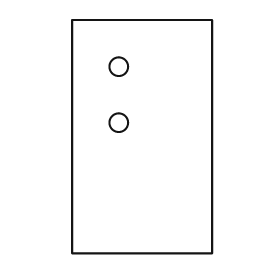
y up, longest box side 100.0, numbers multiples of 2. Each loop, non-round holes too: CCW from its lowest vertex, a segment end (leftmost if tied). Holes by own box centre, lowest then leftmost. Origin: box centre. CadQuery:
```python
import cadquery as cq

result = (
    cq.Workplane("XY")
    .moveTo(-30.0, -50.0)
    .lineTo(30.0, -50.0)
    .lineTo(30.0, 50.0)
    .lineTo(-30.0, 50.0)
    .close()
    .moveTo(-10.0, 6.0)
    .circle(4.0)
    .moveTo(-10.0, 30.0)
    .circle(4.0)
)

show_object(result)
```